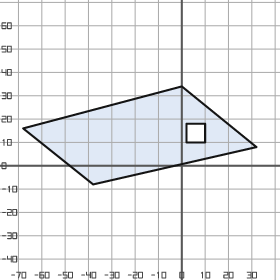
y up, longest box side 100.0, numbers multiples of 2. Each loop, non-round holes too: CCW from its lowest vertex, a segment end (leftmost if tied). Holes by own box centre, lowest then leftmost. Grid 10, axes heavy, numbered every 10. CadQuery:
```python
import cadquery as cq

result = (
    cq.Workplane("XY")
    .moveTo(-38.0, -8.0)
    .lineTo(32.0, 8.0)
    .lineTo(0.0, 34.0)
    .lineTo(-68.0, 16.0)
    .close()
    .moveTo(2.0, 10.0)
    .lineTo(10.0, 10.0)
    .lineTo(10.0, 18.0)
    .lineTo(2.0, 18.0)
    .close()
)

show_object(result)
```